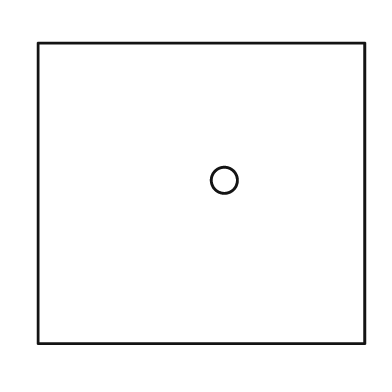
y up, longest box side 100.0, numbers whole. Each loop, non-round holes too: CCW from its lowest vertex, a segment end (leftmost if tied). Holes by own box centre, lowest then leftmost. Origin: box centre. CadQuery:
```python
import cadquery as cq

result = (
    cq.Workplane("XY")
    .moveTo(-50.0, -46.0)
    .lineTo(50.0, -46.0)
    .lineTo(50.0, 46.0)
    .lineTo(-50.0, 46.0)
    .close()
    .moveTo(7.0, 4.0)
    .circle(4.0)
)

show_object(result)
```